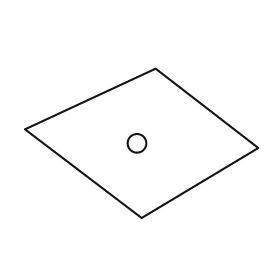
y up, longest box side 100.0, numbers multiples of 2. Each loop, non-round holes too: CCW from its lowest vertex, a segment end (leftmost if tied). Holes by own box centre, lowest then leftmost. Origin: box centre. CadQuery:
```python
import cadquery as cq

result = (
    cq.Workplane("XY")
    .moveTo(0.0, -32.0)
    .lineTo(50.0, -2.0)
    .lineTo(6.0, 32.0)
    .lineTo(-50.0, 6.0)
    .close()
    .moveTo(-2.0, 0.0)
    .circle(4.0)
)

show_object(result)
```